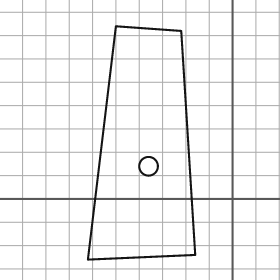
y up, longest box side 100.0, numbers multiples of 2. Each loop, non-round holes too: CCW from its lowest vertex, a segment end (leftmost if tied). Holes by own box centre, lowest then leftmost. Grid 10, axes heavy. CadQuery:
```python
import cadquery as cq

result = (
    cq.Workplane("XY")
    .moveTo(-62.0, -26.0)
    .lineTo(-16.0, -24.0)
    .lineTo(-22.0, 72.0)
    .lineTo(-50.0, 74.0)
    .close()
    .moveTo(-36.0, 14.0)
    .circle(4.0)
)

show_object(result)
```